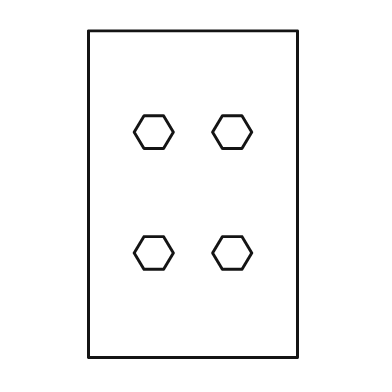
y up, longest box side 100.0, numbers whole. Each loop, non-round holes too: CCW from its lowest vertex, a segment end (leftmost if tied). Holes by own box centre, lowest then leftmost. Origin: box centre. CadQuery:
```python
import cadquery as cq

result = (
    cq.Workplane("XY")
    .moveTo(-32.0, -50.0)
    .lineTo(32.0, -50.0)
    .lineTo(32.0, 50.0)
    .lineTo(-32.0, 50.0)
    .close()
    .moveTo(-15.0, -23.0)
    .lineTo(-9.0, -23.0)
    .lineTo(-6.0, -18.0)
    .lineTo(-9.0, -13.0)
    .lineTo(-15.0, -13.0)
    .lineTo(-18.0, -18.0)
    .close()
    .moveTo(9.0, -23.0)
    .lineTo(15.0, -23.0)
    .lineTo(18.0, -18.0)
    .lineTo(15.0, -13.0)
    .lineTo(9.0, -13.0)
    .lineTo(6.0, -18.0)
    .close()
    .moveTo(-15.0, 14.0)
    .lineTo(-9.0, 14.0)
    .lineTo(-6.0, 19.0)
    .lineTo(-9.0, 24.0)
    .lineTo(-15.0, 24.0)
    .lineTo(-18.0, 19.0)
    .close()
    .moveTo(9.0, 14.0)
    .lineTo(15.0, 14.0)
    .lineTo(18.0, 19.0)
    .lineTo(15.0, 24.0)
    .lineTo(9.0, 24.0)
    .lineTo(6.0, 19.0)
    .close()
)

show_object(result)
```